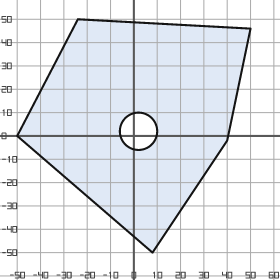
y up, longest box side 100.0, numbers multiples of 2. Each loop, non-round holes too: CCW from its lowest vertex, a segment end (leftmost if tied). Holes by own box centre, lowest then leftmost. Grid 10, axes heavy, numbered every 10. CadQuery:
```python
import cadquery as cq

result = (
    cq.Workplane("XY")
    .moveTo(8.0, -50.0)
    .lineTo(40.0, -2.0)
    .lineTo(50.0, 46.0)
    .lineTo(-24.0, 50.0)
    .lineTo(-50.0, 0.0)
    .close()
    .moveTo(2.0, 2.0)
    .circle(8.0)
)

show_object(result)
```